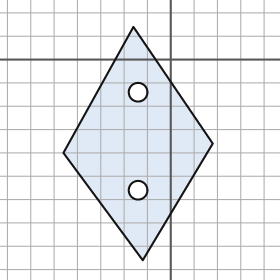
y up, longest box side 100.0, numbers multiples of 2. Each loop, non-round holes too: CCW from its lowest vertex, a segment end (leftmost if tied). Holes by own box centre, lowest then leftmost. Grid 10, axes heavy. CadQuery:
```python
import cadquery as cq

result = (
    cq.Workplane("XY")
    .moveTo(-12.0, -86.0)
    .lineTo(18.0, -36.0)
    .lineTo(-16.0, 14.0)
    .lineTo(-46.0, -40.0)
    .close()
    .moveTo(-14.0, -56.0)
    .circle(4.0)
    .moveTo(-14.0, -14.0)
    .circle(4.0)
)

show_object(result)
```